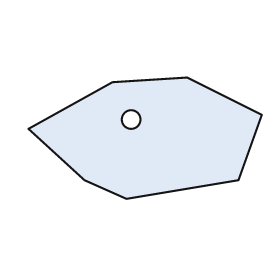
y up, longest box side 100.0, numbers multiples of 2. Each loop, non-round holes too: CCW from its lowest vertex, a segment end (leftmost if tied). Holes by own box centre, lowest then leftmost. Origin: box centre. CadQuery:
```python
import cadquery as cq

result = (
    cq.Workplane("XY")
    .moveTo(-8.0, -26.0)
    .lineTo(40.0, -18.0)
    .lineTo(50.0, 10.0)
    .lineTo(18.0, 26.0)
    .lineTo(-14.0, 24.0)
    .lineTo(-50.0, 4.0)
    .lineTo(-26.0, -18.0)
    .close()
    .moveTo(-6.0, 8.0)
    .circle(4.0)
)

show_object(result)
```